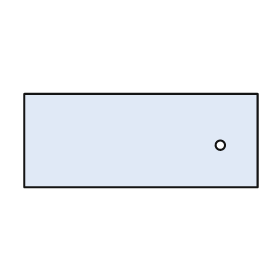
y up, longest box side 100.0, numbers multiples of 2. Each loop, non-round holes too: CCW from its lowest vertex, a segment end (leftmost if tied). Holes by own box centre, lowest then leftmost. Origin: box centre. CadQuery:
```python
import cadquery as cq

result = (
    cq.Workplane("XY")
    .moveTo(-50.0, -20.0)
    .lineTo(50.0, -20.0)
    .lineTo(50.0, 20.0)
    .lineTo(-50.0, 20.0)
    .close()
    .moveTo(34.0, -2.0)
    .circle(2.0)
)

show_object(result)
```